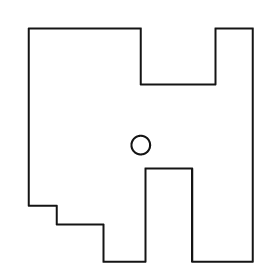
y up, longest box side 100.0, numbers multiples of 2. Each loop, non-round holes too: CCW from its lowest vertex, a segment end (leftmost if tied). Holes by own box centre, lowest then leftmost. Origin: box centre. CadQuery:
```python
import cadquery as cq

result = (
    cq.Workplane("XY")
    .moveTo(-16.0, -50.0)
    .lineTo(2.0, -50.0)
    .lineTo(2.0, -10.0)
    .lineTo(22.0, -10.0)
    .lineTo(22.0, -50.0)
    .lineTo(48.0, -50.0)
    .lineTo(48.0, 50.0)
    .lineTo(32.0, 50.0)
    .lineTo(32.0, 26.0)
    .lineTo(0.0, 26.0)
    .lineTo(0.0, 50.0)
    .lineTo(-48.0, 50.0)
    .lineTo(-48.0, -26.0)
    .lineTo(-36.0, -26.0)
    .lineTo(-36.0, -34.0)
    .lineTo(-16.0, -34.0)
    .close()
    .moveTo(0.0, 0.0)
    .circle(4.0)
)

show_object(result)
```